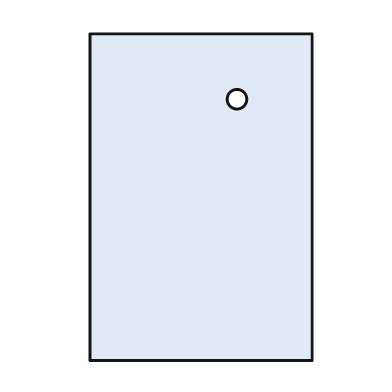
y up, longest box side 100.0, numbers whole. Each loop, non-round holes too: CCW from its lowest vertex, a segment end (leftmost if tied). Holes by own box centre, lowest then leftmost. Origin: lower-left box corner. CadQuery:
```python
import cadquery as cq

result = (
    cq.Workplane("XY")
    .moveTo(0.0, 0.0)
    .lineTo(68.0, 0.0)
    .lineTo(68.0, 100.0)
    .lineTo(0.0, 100.0)
    .close()
    .moveTo(45.0, 80.0)
    .circle(3.0)
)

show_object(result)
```